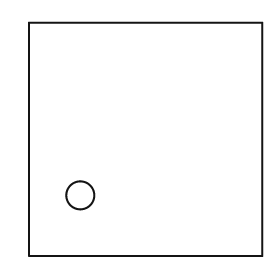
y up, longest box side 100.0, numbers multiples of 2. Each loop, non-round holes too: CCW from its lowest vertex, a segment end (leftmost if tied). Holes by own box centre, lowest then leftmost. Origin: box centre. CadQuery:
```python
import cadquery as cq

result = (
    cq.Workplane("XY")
    .moveTo(-50.0, -50.0)
    .lineTo(50.0, -50.0)
    .lineTo(50.0, 50.0)
    .lineTo(-50.0, 50.0)
    .close()
    .moveTo(-28.0, -24.0)
    .circle(6.0)
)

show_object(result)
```